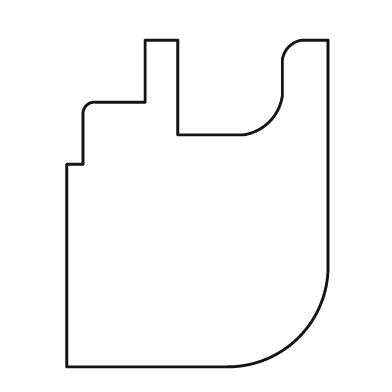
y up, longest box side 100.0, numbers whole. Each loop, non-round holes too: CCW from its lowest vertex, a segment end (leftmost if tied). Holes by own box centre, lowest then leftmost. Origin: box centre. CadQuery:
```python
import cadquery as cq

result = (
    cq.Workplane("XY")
    .moveTo(-40.0, -50.0)
    .lineTo(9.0, -50.0)
    .threePointArc((31.0, -41.0), (40.0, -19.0))
    .lineTo(40.0, 50.0)
    .lineTo(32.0, 50.0)
    .threePointArc((28.0, 48.0), (26.0, 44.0))
    .lineTo(26.0, 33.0)
    .threePointArc((22.0, 25.0), (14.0, 21.0))
    .lineTo(-6.0, 21.0)
    .lineTo(-6.0, 50.0)
    .lineTo(-16.0, 50.0)
    .lineTo(-16.0, 31.0)
    .lineTo(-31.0, 31.0)
    .threePointArc((-34.0, 30.0), (-35.0, 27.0))
    .lineTo(-35.0, 12.0)
    .lineTo(-40.0, 12.0)
    .close()
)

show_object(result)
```